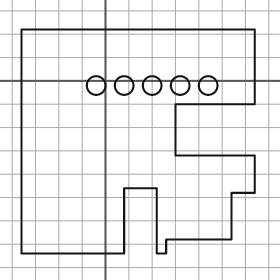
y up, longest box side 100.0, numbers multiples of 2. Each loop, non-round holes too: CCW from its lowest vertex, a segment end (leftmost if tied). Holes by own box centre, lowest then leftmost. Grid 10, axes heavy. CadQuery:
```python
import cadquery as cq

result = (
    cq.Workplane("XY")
    .moveTo(-36.0, -74.0)
    .lineTo(8.0, -74.0)
    .lineTo(8.0, -46.0)
    .lineTo(22.0, -46.0)
    .lineTo(22.0, -74.0)
    .lineTo(26.0, -74.0)
    .lineTo(26.0, -68.0)
    .lineTo(54.0, -68.0)
    .lineTo(54.0, -48.0)
    .lineTo(64.0, -48.0)
    .lineTo(64.0, -32.0)
    .lineTo(30.0, -32.0)
    .lineTo(30.0, -10.0)
    .lineTo(64.0, -10.0)
    .lineTo(64.0, 22.0)
    .lineTo(-36.0, 22.0)
    .close()
    .moveTo(-4.0, -2.0)
    .circle(4.0)
    .moveTo(8.0, -2.0)
    .circle(4.0)
    .moveTo(20.0, -2.0)
    .circle(4.0)
    .moveTo(32.0, -2.0)
    .circle(4.0)
    .moveTo(44.0, -2.0)
    .circle(4.0)
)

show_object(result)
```